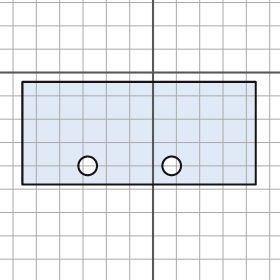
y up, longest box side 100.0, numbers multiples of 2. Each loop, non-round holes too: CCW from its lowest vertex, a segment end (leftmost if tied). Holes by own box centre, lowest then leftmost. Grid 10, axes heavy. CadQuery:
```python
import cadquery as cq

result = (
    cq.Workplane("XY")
    .moveTo(-56.0, -48.0)
    .lineTo(44.0, -48.0)
    .lineTo(44.0, -4.0)
    .lineTo(-56.0, -4.0)
    .close()
    .moveTo(-28.0, -40.0)
    .circle(4.0)
    .moveTo(8.0, -40.0)
    .circle(4.0)
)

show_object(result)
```